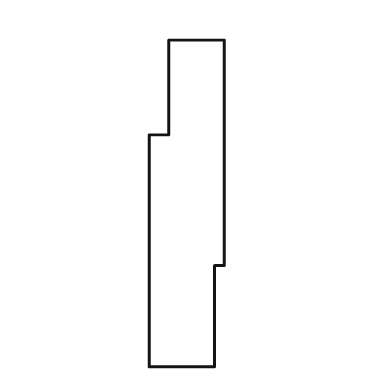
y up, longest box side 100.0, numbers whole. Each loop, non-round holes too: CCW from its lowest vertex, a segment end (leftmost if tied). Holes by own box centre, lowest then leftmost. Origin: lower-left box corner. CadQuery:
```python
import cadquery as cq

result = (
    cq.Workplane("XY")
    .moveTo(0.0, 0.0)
    .lineTo(20.0, 0.0)
    .lineTo(20.0, 31.0)
    .lineTo(23.0, 31.0)
    .lineTo(23.0, 100.0)
    .lineTo(6.0, 100.0)
    .lineTo(6.0, 71.0)
    .lineTo(0.0, 71.0)
    .close()
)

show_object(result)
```